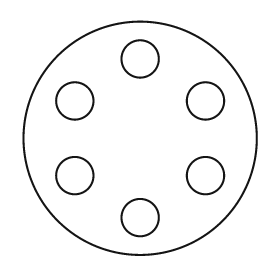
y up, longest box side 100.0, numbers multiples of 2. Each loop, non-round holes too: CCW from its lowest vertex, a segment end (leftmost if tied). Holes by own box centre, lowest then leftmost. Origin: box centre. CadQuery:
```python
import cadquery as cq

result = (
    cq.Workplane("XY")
    .moveTo(0.0, 0.0)
    .circle(50.0)
    .moveTo(0.0, -34.0)
    .circle(8.0)
    .moveTo(-28.0, -16.0)
    .circle(8.0)
    .moveTo(28.0, -16.0)
    .circle(8.0)
    .moveTo(-28.0, 16.0)
    .circle(8.0)
    .moveTo(28.0, 16.0)
    .circle(8.0)
    .moveTo(0.0, 34.0)
    .circle(8.0)
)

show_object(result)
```